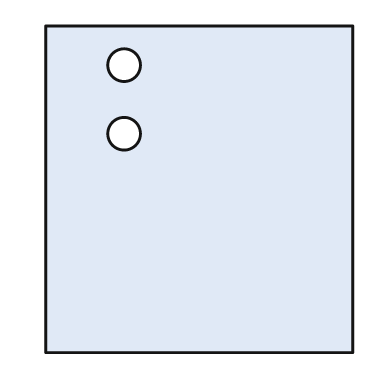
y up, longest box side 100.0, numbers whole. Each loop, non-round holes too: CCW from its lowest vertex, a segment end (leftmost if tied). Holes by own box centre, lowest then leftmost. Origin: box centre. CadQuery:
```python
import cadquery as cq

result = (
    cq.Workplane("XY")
    .moveTo(-47.0, -50.0)
    .lineTo(47.0, -50.0)
    .lineTo(47.0, 50.0)
    .lineTo(-47.0, 50.0)
    .close()
    .moveTo(-23.0, 17.0)
    .circle(5.0)
    .moveTo(-23.0, 38.0)
    .circle(5.0)
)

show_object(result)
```